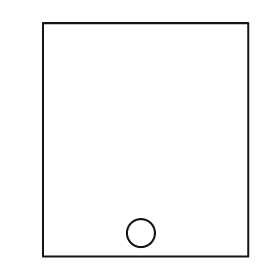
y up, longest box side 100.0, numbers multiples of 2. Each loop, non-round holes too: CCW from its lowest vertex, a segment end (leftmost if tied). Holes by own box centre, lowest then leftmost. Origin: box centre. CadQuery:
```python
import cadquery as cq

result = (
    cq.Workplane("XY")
    .moveTo(-44.0, -50.0)
    .lineTo(44.0, -50.0)
    .lineTo(44.0, 50.0)
    .lineTo(-44.0, 50.0)
    .close()
    .moveTo(-2.0, -40.0)
    .circle(6.0)
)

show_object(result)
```